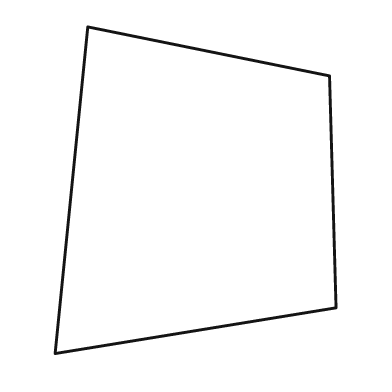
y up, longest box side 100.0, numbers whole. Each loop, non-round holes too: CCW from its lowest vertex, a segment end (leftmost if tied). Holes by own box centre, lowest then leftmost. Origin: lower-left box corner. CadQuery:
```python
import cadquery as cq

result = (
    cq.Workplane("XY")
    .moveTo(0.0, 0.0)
    .lineTo(86.0, 14.0)
    .lineTo(84.0, 85.0)
    .lineTo(10.0, 100.0)
    .close()
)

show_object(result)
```